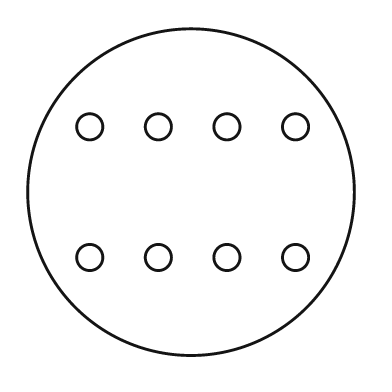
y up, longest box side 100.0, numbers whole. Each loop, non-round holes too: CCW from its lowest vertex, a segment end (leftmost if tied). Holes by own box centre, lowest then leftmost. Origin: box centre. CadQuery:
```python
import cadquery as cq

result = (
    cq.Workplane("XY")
    .moveTo(0.0, 0.0)
    .circle(50.0)
    .moveTo(-31.0, -20.0)
    .circle(4.0)
    .moveTo(-10.0, -20.0)
    .circle(4.0)
    .moveTo(11.0, -20.0)
    .circle(4.0)
    .moveTo(32.0, -20.0)
    .circle(4.0)
    .moveTo(-31.0, 20.0)
    .circle(4.0)
    .moveTo(-10.0, 20.0)
    .circle(4.0)
    .moveTo(11.0, 20.0)
    .circle(4.0)
    .moveTo(32.0, 20.0)
    .circle(4.0)
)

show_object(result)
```